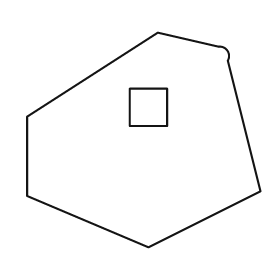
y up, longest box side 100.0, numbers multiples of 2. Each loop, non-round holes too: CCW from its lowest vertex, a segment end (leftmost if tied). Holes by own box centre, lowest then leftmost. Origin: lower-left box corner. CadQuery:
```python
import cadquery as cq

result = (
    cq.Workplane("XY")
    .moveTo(52.0, 0.0)
    .lineTo(100.0, 24.0)
    .lineTo(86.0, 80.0)
    .threePointArc((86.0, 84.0), (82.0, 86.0))
    .lineTo(56.0, 92.0)
    .lineTo(0.0, 56.0)
    .lineTo(0.0, 22.0)
    .close()
    .moveTo(44.0, 52.0)
    .lineTo(60.0, 52.0)
    .lineTo(60.0, 68.0)
    .lineTo(44.0, 68.0)
    .close()
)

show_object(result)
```